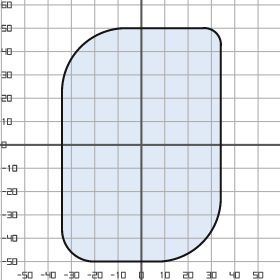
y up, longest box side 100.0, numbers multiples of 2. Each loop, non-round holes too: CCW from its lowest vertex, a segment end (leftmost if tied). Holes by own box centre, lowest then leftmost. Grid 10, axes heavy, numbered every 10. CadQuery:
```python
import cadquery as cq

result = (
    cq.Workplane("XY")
    .moveTo(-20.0, -50.0)
    .lineTo(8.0, -50.0)
    .threePointArc((26.0, -42.0), (34.0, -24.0))
    .lineTo(34.0, 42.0)
    .threePointArc((32.0, 48.0), (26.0, 50.0))
    .lineTo(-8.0, 50.0)
    .threePointArc((-26.0, 42.0), (-34.0, 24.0))
    .lineTo(-34.0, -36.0)
    .threePointArc((-30.0, -46.0), (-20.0, -50.0))
    .close()
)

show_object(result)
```